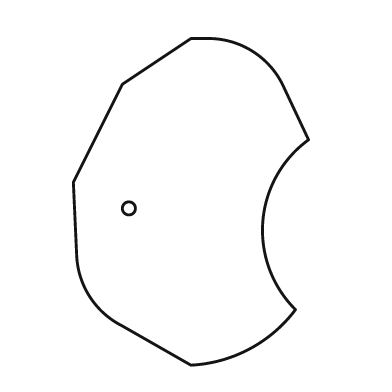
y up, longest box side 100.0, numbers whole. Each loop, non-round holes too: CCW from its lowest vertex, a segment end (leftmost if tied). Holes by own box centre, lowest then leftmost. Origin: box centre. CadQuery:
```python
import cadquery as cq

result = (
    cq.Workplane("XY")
    .moveTo(0.0, -50.0)
    .threePointArc((18.0, -45.0), (32.0, -33.0))
    .threePointArc((22.0, -6.0), (36.0, 19.0))
    .lineTo(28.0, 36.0)
    .threePointArc((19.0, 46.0), (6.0, 50.0))
    .lineTo(0.0, 50.0)
    .lineTo(-21.0, 36.0)
    .lineTo(-36.0, 6.0)
    .lineTo(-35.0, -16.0)
    .threePointArc((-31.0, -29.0), (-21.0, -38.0))
    .close()
    .moveTo(-19.0, -2.0)
    .circle(2.0)
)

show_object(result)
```